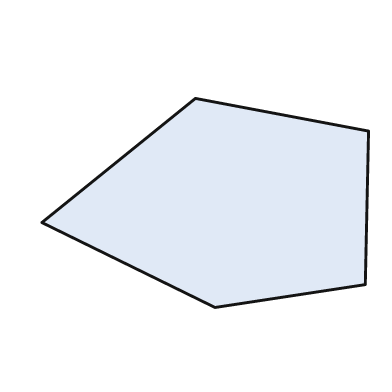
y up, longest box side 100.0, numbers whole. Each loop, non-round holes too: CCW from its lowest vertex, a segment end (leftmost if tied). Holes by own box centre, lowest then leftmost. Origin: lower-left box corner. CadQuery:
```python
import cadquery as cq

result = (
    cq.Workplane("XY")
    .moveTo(53.0, 0.0)
    .lineTo(99.0, 7.0)
    .lineTo(100.0, 54.0)
    .lineTo(47.0, 64.0)
    .lineTo(0.0, 26.0)
    .close()
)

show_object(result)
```